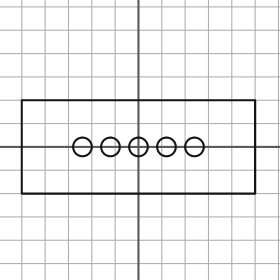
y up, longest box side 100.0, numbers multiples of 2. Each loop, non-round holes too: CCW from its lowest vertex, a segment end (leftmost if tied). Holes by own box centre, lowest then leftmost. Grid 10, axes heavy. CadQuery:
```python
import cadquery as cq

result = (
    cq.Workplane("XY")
    .moveTo(-50.0, -20.0)
    .lineTo(50.0, -20.0)
    .lineTo(50.0, 20.0)
    .lineTo(-50.0, 20.0)
    .close()
    .moveTo(-24.0, 0.0)
    .circle(4.0)
    .moveTo(-12.0, 0.0)
    .circle(4.0)
    .moveTo(0.0, 0.0)
    .circle(4.0)
    .moveTo(12.0, 0.0)
    .circle(4.0)
    .moveTo(24.0, 0.0)
    .circle(4.0)
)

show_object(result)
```